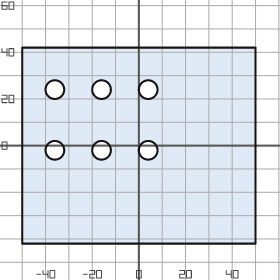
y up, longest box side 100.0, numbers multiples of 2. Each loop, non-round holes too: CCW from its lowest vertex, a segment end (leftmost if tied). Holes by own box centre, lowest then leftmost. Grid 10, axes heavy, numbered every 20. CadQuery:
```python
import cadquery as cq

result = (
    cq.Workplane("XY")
    .moveTo(-50.0, -42.0)
    .lineTo(50.0, -42.0)
    .lineTo(50.0, 42.0)
    .lineTo(-50.0, 42.0)
    .close()
    .moveTo(-36.0, -2.0)
    .circle(4.0)
    .moveTo(-16.0, -2.0)
    .circle(4.0)
    .moveTo(4.0, -2.0)
    .circle(4.0)
    .moveTo(-36.0, 24.0)
    .circle(4.0)
    .moveTo(-16.0, 24.0)
    .circle(4.0)
    .moveTo(4.0, 24.0)
    .circle(4.0)
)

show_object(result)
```